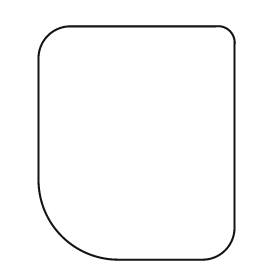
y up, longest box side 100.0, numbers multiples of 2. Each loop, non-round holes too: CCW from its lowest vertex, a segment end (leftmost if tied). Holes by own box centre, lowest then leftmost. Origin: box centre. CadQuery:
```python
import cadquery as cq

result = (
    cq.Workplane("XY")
    .moveTo(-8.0, -50.0)
    .lineTo(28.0, -50.0)
    .threePointArc((38.0, -46.0), (42.0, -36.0))
    .lineTo(42.0, 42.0)
    .threePointArc((40.0, 48.0), (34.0, 50.0))
    .lineTo(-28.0, 50.0)
    .threePointArc((-38.0, 46.0), (-42.0, 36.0))
    .lineTo(-42.0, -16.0)
    .threePointArc((-32.0, -40.0), (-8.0, -50.0))
    .close()
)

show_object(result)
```